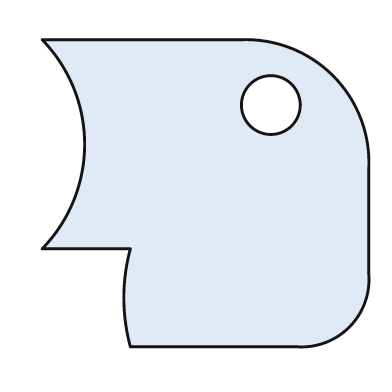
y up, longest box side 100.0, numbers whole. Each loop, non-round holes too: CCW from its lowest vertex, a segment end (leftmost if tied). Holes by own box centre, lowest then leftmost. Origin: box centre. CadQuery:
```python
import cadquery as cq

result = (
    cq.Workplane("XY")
    .moveTo(-23.0, -47.0)
    .lineTo(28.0, -47.0)
    .threePointArc((44.0, -41.0), (50.0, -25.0))
    .lineTo(50.0, 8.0)
    .threePointArc((39.0, 36.0), (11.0, 47.0))
    .lineTo(-50.0, 47.0)
    .threePointArc((-37.0, 15.0), (-50.0, -17.0))
    .lineTo(-23.0, -17.0)
    .threePointArc((-25.0, -32.0), (-23.0, -47.0))
    .close()
    .moveTo(20.0, 27.0)
    .circle(9.0)
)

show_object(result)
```